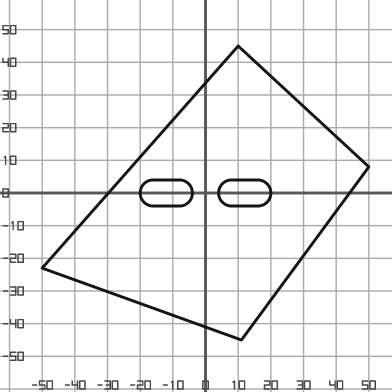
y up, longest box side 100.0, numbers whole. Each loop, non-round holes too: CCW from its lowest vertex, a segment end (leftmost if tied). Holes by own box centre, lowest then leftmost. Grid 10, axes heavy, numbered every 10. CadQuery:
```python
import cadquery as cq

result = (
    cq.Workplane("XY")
    .moveTo(11.0, -45.0)
    .lineTo(50.0, 8.0)
    .lineTo(10.0, 45.0)
    .lineTo(-50.0, -23.0)
    .close()
    .moveTo(-16.0, -4.0)
    .lineTo(-8.0, -4.0)
    .threePointArc((-4.0, 0.0), (-8.0, 4.0))
    .lineTo(-16.0, 4.0)
    .threePointArc((-20.0, 0.0), (-16.0, -4.0))
    .close()
    .moveTo(8.0, -4.0)
    .lineTo(16.0, -4.0)
    .threePointArc((20.0, 0.0), (16.0, 4.0))
    .lineTo(8.0, 4.0)
    .threePointArc((4.0, 0.0), (8.0, -4.0))
    .close()
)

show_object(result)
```